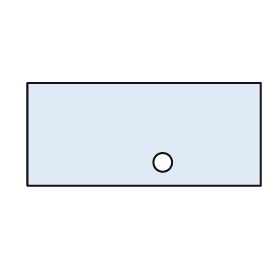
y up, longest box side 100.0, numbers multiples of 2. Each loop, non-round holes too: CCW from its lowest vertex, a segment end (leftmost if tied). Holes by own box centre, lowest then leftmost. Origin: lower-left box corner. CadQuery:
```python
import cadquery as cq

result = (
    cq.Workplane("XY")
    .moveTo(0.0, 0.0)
    .lineTo(100.0, 0.0)
    .lineTo(100.0, 44.0)
    .lineTo(0.0, 44.0)
    .close()
    .moveTo(58.0, 10.0)
    .circle(4.0)
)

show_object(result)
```